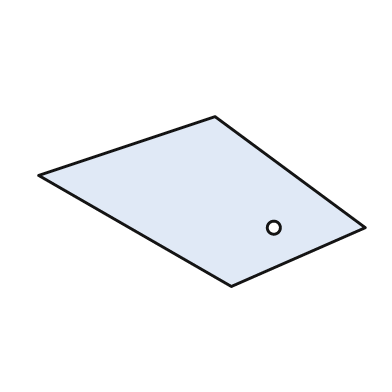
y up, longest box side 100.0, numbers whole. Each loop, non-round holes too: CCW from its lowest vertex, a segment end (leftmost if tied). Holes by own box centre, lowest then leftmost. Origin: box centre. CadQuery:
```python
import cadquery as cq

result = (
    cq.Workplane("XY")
    .moveTo(9.0, -26.0)
    .lineTo(50.0, -8.0)
    .lineTo(4.0, 26.0)
    .lineTo(-50.0, 8.0)
    .close()
    .moveTo(22.0, -8.0)
    .circle(2.0)
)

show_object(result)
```